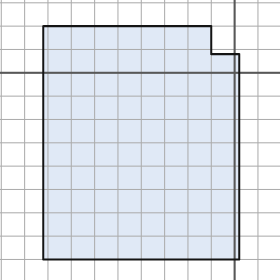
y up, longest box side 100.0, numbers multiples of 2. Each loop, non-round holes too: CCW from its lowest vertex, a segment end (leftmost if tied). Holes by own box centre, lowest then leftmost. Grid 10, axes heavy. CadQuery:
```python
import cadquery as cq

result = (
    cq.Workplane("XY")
    .moveTo(-82.0, -80.0)
    .lineTo(2.0, -80.0)
    .lineTo(2.0, 8.0)
    .lineTo(-10.0, 8.0)
    .lineTo(-10.0, 20.0)
    .lineTo(-82.0, 20.0)
    .close()
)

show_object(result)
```